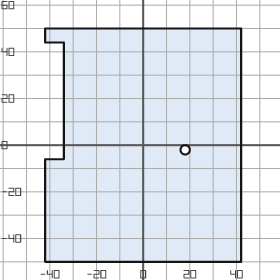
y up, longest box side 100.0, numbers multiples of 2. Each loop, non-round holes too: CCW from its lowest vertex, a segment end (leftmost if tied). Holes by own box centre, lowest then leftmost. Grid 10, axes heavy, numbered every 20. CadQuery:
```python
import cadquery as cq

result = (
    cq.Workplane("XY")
    .moveTo(-42.0, -50.0)
    .lineTo(42.0, -50.0)
    .lineTo(42.0, 50.0)
    .lineTo(-42.0, 50.0)
    .lineTo(-42.0, 44.0)
    .lineTo(-34.0, 44.0)
    .lineTo(-34.0, -6.0)
    .lineTo(-42.0, -6.0)
    .close()
    .moveTo(18.0, -2.0)
    .circle(2.0)
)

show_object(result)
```